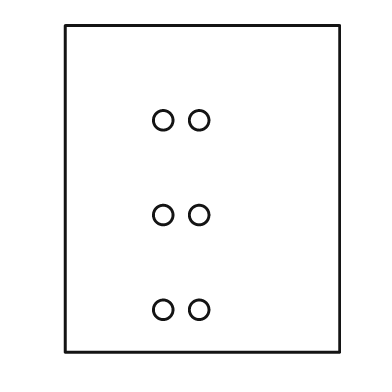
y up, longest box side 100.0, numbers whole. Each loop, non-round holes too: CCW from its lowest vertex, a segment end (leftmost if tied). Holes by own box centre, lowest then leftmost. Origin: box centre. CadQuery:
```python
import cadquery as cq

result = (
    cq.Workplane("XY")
    .moveTo(-42.0, -50.0)
    .lineTo(42.0, -50.0)
    .lineTo(42.0, 50.0)
    .lineTo(-42.0, 50.0)
    .close()
    .moveTo(-12.0, -37.0)
    .circle(3.0)
    .moveTo(-1.0, -37.0)
    .circle(3.0)
    .moveTo(-12.0, -8.0)
    .circle(3.0)
    .moveTo(-1.0, -8.0)
    .circle(3.0)
    .moveTo(-12.0, 21.0)
    .circle(3.0)
    .moveTo(-1.0, 21.0)
    .circle(3.0)
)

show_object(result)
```